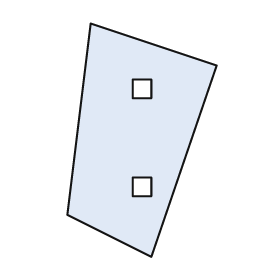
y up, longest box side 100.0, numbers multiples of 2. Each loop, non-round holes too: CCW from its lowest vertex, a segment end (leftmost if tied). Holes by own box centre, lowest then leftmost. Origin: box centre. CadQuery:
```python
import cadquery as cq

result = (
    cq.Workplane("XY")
    .moveTo(4.0, -50.0)
    .lineTo(32.0, 32.0)
    .lineTo(-22.0, 50.0)
    .lineTo(-32.0, -32.0)
    .close()
    .moveTo(-4.0, -24.0)
    .lineTo(4.0, -24.0)
    .lineTo(4.0, -16.0)
    .lineTo(-4.0, -16.0)
    .close()
    .moveTo(-4.0, 18.0)
    .lineTo(4.0, 18.0)
    .lineTo(4.0, 26.0)
    .lineTo(-4.0, 26.0)
    .close()
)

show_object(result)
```